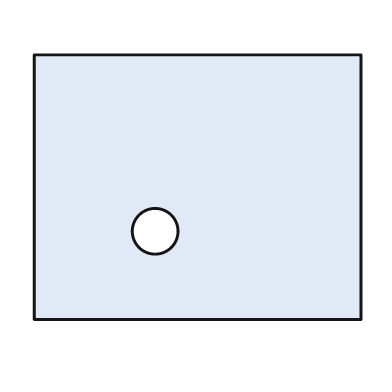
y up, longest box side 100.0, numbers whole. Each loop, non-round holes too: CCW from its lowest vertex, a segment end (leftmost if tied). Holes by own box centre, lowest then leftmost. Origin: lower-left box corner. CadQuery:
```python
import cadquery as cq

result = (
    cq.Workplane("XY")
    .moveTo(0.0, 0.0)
    .lineTo(100.0, 0.0)
    .lineTo(100.0, 81.0)
    .lineTo(0.0, 81.0)
    .close()
    .moveTo(37.0, 27.0)
    .circle(7.0)
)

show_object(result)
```